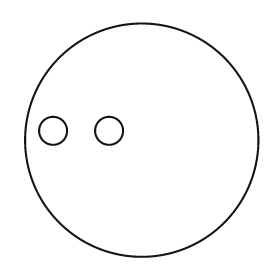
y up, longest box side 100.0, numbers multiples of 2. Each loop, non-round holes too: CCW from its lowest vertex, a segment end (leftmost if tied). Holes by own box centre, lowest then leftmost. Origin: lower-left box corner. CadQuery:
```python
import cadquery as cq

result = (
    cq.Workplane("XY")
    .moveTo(50.0, 50.0)
    .circle(50.0)
    .moveTo(12.0, 54.0)
    .circle(6.0)
    .moveTo(36.0, 54.0)
    .circle(6.0)
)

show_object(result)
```